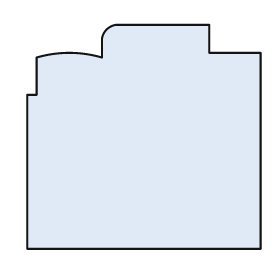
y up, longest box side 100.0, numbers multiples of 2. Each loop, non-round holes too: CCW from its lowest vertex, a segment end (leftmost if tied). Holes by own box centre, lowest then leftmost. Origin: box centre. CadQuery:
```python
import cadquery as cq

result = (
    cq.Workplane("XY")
    .moveTo(-50.0, -48.0)
    .lineTo(50.0, -48.0)
    .lineTo(50.0, 36.0)
    .lineTo(28.0, 36.0)
    .lineTo(28.0, 48.0)
    .lineTo(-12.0, 48.0)
    .threePointArc((-16.0, 46.0), (-18.0, 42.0))
    .lineTo(-18.0, 34.0)
    .threePointArc((-32.0, 36.0), (-46.0, 34.0))
    .lineTo(-46.0, 18.0)
    .lineTo(-50.0, 18.0)
    .close()
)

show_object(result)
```